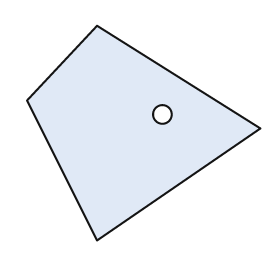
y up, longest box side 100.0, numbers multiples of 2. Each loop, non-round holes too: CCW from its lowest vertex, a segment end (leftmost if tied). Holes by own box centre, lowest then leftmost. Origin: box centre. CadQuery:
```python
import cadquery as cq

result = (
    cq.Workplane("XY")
    .moveTo(-20.0, -46.0)
    .lineTo(50.0, 2.0)
    .lineTo(-20.0, 46.0)
    .lineTo(-50.0, 14.0)
    .close()
    .moveTo(8.0, 8.0)
    .circle(4.0)
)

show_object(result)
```